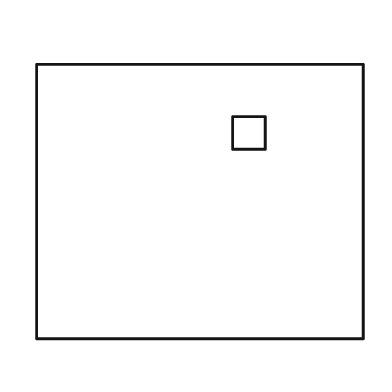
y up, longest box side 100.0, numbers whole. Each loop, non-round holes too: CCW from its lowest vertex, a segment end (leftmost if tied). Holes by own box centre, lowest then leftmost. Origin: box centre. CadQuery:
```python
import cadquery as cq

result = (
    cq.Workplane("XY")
    .moveTo(-50.0, -42.0)
    .lineTo(50.0, -42.0)
    .lineTo(50.0, 42.0)
    .lineTo(-50.0, 42.0)
    .close()
    .moveTo(10.0, 16.0)
    .lineTo(20.0, 16.0)
    .lineTo(20.0, 26.0)
    .lineTo(10.0, 26.0)
    .close()
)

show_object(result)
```